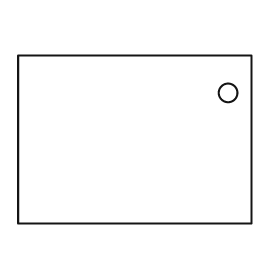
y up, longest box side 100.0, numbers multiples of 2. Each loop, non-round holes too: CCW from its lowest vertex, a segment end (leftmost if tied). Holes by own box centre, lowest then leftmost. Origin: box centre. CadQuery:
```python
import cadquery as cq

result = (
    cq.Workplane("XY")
    .moveTo(-50.0, -36.0)
    .lineTo(50.0, -36.0)
    .lineTo(50.0, 36.0)
    .lineTo(-50.0, 36.0)
    .close()
    .moveTo(40.0, 20.0)
    .circle(4.0)
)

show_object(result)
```